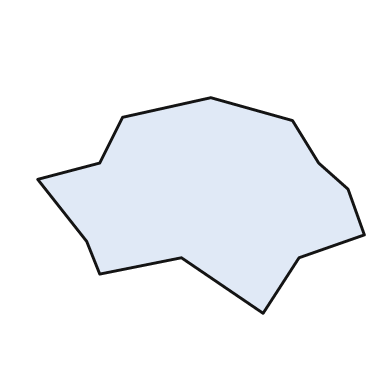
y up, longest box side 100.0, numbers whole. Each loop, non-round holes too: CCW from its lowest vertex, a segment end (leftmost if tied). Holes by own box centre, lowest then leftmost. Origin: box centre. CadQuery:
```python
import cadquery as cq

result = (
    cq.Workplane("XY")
    .moveTo(19.0, -33.0)
    .lineTo(30.0, -16.0)
    .lineTo(50.0, -9.0)
    .lineTo(45.0, 5.0)
    .lineTo(36.0, 13.0)
    .lineTo(28.0, 26.0)
    .lineTo(3.0, 33.0)
    .lineTo(-24.0, 27.0)
    .lineTo(-31.0, 13.0)
    .lineTo(-50.0, 8.0)
    .lineTo(-35.0, -11.0)
    .lineTo(-31.0, -21.0)
    .lineTo(-6.0, -16.0)
    .close()
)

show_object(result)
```